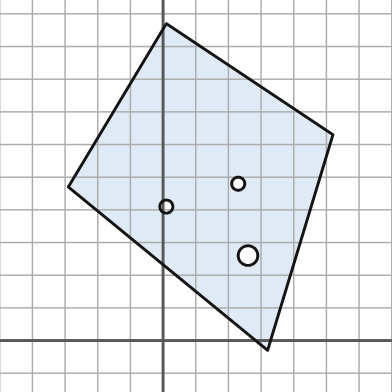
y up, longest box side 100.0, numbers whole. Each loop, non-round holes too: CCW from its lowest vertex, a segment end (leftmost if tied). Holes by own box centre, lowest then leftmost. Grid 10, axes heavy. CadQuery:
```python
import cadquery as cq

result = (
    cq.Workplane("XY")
    .moveTo(32.0, -3.0)
    .lineTo(52.0, 63.0)
    .lineTo(1.0, 97.0)
    .lineTo(-29.0, 47.0)
    .close()
    .moveTo(26.0, 26.0)
    .circle(3.0)
    .moveTo(1.0, 41.0)
    .circle(2.0)
    .moveTo(23.0, 48.0)
    .circle(2.0)
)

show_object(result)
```